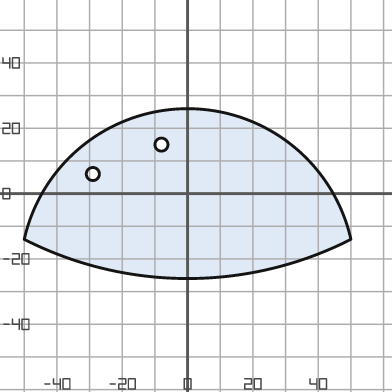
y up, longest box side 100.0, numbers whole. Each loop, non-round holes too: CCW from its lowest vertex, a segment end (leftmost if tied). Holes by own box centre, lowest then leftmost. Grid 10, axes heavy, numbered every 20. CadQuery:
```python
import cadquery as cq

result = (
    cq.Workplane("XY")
    .moveTo(-50.0, -14.0)
    .threePointArc((0.0, -26.0), (50.0, -14.0))
    .threePointArc((0.0, 26.0), (-50.0, -14.0))
    .close()
    .moveTo(-29.0, 6.0)
    .circle(2.0)
    .moveTo(-8.0, 15.0)
    .circle(2.0)
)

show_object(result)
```